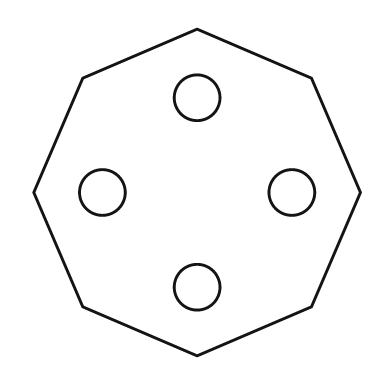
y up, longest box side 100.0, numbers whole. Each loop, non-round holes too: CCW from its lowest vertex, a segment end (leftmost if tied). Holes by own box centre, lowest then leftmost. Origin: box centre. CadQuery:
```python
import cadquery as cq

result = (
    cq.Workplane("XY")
    .moveTo(0.0, -50.0)
    .lineTo(35.0, -35.0)
    .lineTo(50.0, 0.0)
    .lineTo(35.0, 35.0)
    .lineTo(0.0, 50.0)
    .lineTo(-35.0, 35.0)
    .lineTo(-50.0, 0.0)
    .lineTo(-35.0, -35.0)
    .close()
    .moveTo(0.0, -29.0)
    .circle(7.0)
    .moveTo(-29.0, 0.0)
    .circle(7.0)
    .moveTo(29.0, 0.0)
    .circle(7.0)
    .moveTo(0.0, 29.0)
    .circle(7.0)
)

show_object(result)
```